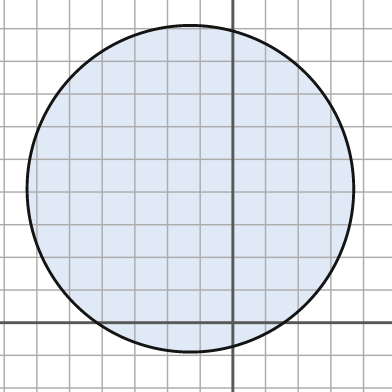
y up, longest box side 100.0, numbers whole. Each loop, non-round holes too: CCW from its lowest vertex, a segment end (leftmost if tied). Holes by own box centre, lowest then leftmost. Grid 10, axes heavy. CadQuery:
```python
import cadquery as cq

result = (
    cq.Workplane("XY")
    .moveTo(-13.0, 41.0)
    .circle(50.0)
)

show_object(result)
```